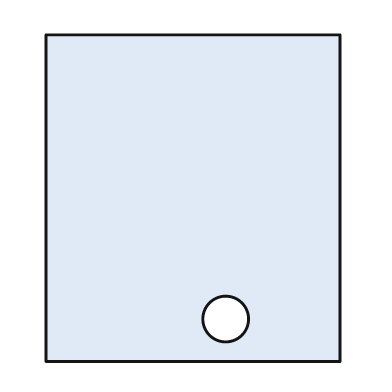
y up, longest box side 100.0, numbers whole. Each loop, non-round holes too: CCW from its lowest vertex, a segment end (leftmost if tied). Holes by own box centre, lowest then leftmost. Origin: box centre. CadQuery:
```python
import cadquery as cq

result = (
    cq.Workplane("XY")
    .moveTo(-45.0, -50.0)
    .lineTo(45.0, -50.0)
    .lineTo(45.0, 50.0)
    .lineTo(-45.0, 50.0)
    .close()
    .moveTo(10.0, -37.0)
    .circle(7.0)
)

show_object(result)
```